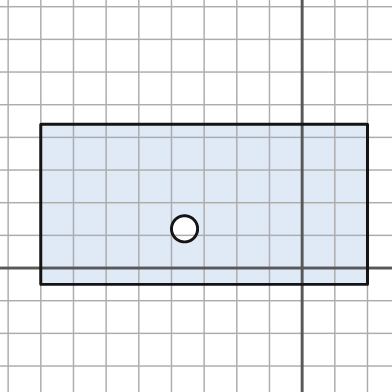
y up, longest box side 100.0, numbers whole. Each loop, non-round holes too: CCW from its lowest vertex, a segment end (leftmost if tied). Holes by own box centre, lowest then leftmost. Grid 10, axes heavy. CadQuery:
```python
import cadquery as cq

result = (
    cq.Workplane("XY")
    .moveTo(-80.0, -5.0)
    .lineTo(20.0, -5.0)
    .lineTo(20.0, 44.0)
    .lineTo(-80.0, 44.0)
    .close()
    .moveTo(-36.0, 12.0)
    .circle(4.0)
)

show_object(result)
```